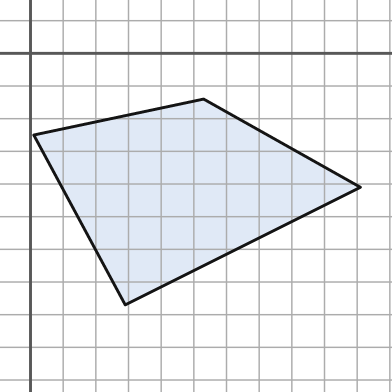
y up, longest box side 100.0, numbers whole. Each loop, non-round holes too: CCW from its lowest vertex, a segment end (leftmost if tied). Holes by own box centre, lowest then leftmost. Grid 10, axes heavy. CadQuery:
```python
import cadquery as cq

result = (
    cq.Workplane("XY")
    .moveTo(29.0, -77.0)
    .lineTo(101.0, -41.0)
    .lineTo(53.0, -14.0)
    .lineTo(1.0, -25.0)
    .close()
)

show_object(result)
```